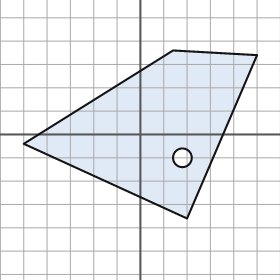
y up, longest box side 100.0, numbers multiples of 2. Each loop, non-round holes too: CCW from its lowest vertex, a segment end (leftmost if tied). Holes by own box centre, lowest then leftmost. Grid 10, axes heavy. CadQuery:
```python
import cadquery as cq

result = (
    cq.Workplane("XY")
    .moveTo(20.0, -36.0)
    .lineTo(50.0, 34.0)
    .lineTo(14.0, 36.0)
    .lineTo(-50.0, -4.0)
    .close()
    .moveTo(18.0, -10.0)
    .circle(4.0)
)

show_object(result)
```